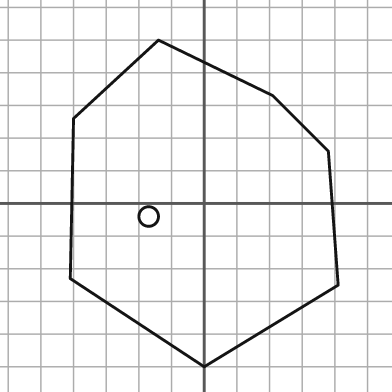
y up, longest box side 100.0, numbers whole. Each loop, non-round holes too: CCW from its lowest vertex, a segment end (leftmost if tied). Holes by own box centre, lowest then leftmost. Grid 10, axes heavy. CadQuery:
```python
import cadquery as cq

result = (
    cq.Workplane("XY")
    .moveTo(0.0, -50.0)
    .lineTo(41.0, -25.0)
    .lineTo(38.0, 16.0)
    .lineTo(21.0, 33.0)
    .lineTo(-14.0, 50.0)
    .lineTo(-40.0, 26.0)
    .lineTo(-41.0, -23.0)
    .close()
    .moveTo(-17.0, -4.0)
    .circle(3.0)
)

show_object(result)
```